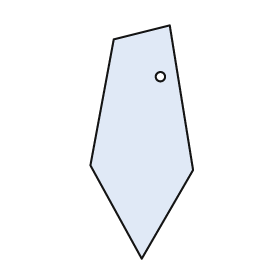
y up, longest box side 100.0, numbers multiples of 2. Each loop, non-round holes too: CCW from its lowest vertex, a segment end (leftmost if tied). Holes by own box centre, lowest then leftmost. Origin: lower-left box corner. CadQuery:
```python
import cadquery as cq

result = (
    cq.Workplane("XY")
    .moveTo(22.0, 0.0)
    .lineTo(44.0, 38.0)
    .lineTo(34.0, 100.0)
    .lineTo(10.0, 94.0)
    .lineTo(0.0, 40.0)
    .close()
    .moveTo(30.0, 78.0)
    .circle(2.0)
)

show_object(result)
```